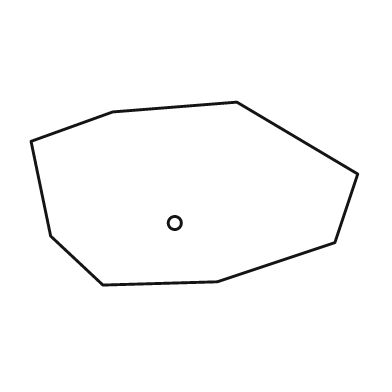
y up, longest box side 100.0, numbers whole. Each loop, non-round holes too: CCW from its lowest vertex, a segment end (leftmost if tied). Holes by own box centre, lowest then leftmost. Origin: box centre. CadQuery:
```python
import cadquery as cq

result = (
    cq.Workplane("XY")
    .moveTo(-28.0, -28.0)
    .lineTo(7.0, -27.0)
    .lineTo(43.0, -15.0)
    .lineTo(50.0, 6.0)
    .lineTo(13.0, 28.0)
    .lineTo(-25.0, 25.0)
    .lineTo(-50.0, 16.0)
    .lineTo(-44.0, -13.0)
    .close()
    .moveTo(-6.0, -9.0)
    .circle(2.0)
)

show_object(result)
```